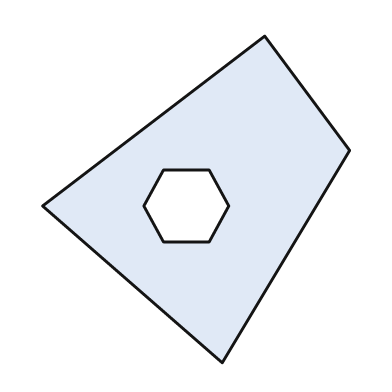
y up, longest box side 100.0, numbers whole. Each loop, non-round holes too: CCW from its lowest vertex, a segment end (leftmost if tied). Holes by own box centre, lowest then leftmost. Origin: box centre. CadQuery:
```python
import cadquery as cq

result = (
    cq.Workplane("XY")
    .moveTo(8.0, -50.0)
    .lineTo(47.0, 15.0)
    .lineTo(21.0, 50.0)
    .lineTo(-47.0, -2.0)
    .close()
    .moveTo(-10.0, -13.0)
    .lineTo(4.0, -13.0)
    .lineTo(10.0, -2.0)
    .lineTo(4.0, 9.0)
    .lineTo(-10.0, 9.0)
    .lineTo(-16.0, -2.0)
    .close()
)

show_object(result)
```